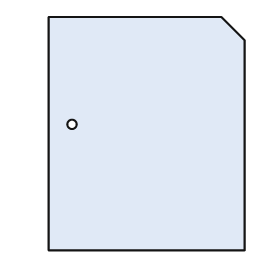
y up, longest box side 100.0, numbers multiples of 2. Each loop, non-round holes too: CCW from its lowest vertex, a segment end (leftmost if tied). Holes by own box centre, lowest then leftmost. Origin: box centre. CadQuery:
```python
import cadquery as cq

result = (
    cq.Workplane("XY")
    .moveTo(-42.0, -50.0)
    .lineTo(42.0, -50.0)
    .lineTo(42.0, 40.0)
    .lineTo(32.0, 50.0)
    .lineTo(-42.0, 50.0)
    .close()
    .moveTo(-32.0, 4.0)
    .circle(2.0)
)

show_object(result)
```